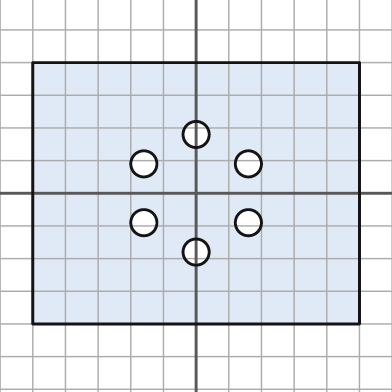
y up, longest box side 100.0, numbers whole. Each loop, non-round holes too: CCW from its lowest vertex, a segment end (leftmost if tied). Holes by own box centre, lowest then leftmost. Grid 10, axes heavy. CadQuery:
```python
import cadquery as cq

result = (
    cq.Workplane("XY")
    .moveTo(-50.0, -40.0)
    .lineTo(50.0, -40.0)
    .lineTo(50.0, 40.0)
    .lineTo(-50.0, 40.0)
    .close()
    .moveTo(0.0, -18.0)
    .circle(4.0)
    .moveTo(-16.0, -9.0)
    .circle(4.0)
    .moveTo(16.0, -9.0)
    .circle(4.0)
    .moveTo(-16.0, 9.0)
    .circle(4.0)
    .moveTo(16.0, 9.0)
    .circle(4.0)
    .moveTo(0.0, 18.0)
    .circle(4.0)
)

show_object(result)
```